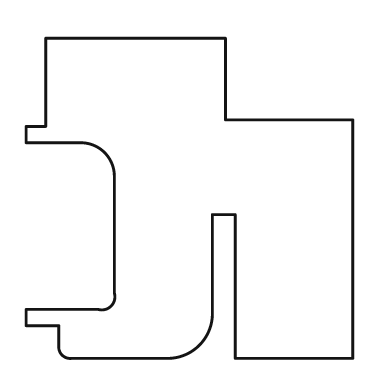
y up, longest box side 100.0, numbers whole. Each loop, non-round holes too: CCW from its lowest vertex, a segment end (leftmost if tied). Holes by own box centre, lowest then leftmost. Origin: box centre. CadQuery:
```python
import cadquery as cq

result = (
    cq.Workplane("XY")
    .moveTo(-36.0, -49.0)
    .lineTo(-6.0, -49.0)
    .threePointArc((3.0, -45.0), (7.0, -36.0))
    .lineTo(7.0, -5.0)
    .lineTo(14.0, -5.0)
    .lineTo(14.0, -49.0)
    .lineTo(50.0, -49.0)
    .lineTo(50.0, 24.0)
    .lineTo(11.0, 24.0)
    .lineTo(11.0, 49.0)
    .lineTo(-44.0, 49.0)
    .lineTo(-44.0, 22.0)
    .lineTo(-50.0, 22.0)
    .lineTo(-50.0, 17.0)
    .lineTo(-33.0, 17.0)
    .threePointArc((-26.0, 14.0), (-23.0, 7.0))
    .lineTo(-23.0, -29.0)
    .threePointArc((-24.0, -33.0), (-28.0, -34.0))
    .lineTo(-50.0, -34.0)
    .lineTo(-50.0, -39.0)
    .lineTo(-40.0, -39.0)
    .lineTo(-40.0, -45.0)
    .threePointArc((-39.0, -48.0), (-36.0, -49.0))
    .close()
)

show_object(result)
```